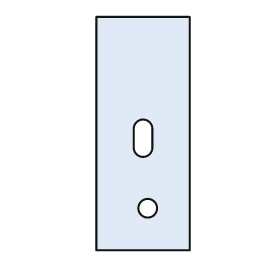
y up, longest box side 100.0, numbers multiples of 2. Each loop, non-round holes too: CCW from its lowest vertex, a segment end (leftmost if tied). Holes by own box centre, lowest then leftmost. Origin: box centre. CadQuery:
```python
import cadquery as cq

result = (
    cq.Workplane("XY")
    .moveTo(-20.0, -50.0)
    .lineTo(20.0, -50.0)
    .lineTo(20.0, 50.0)
    .lineTo(-20.0, 50.0)
    .close()
    .moveTo(2.0, -32.0)
    .circle(4.0)
    .moveTo(-4.0, -6.0)
    .threePointArc((0.0, -10.0), (4.0, -6.0))
    .lineTo(4.0, 2.0)
    .threePointArc((0.0, 6.0), (-4.0, 2.0))
    .close()
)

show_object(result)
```